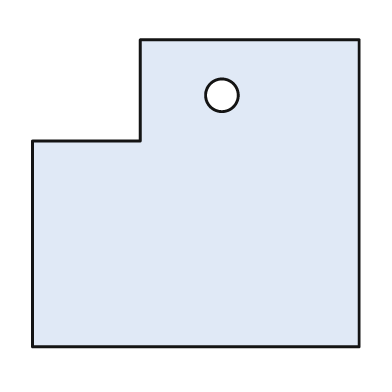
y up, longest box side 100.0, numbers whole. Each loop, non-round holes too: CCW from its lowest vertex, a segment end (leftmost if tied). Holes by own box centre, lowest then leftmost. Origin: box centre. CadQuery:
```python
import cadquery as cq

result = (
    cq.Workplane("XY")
    .moveTo(-50.0, -47.0)
    .lineTo(50.0, -47.0)
    .lineTo(50.0, 47.0)
    .lineTo(-17.0, 47.0)
    .lineTo(-17.0, 16.0)
    .lineTo(-50.0, 16.0)
    .close()
    .moveTo(8.0, 30.0)
    .circle(5.0)
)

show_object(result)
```